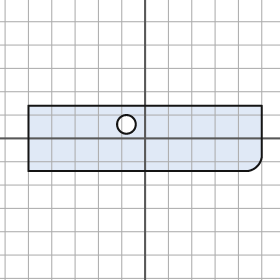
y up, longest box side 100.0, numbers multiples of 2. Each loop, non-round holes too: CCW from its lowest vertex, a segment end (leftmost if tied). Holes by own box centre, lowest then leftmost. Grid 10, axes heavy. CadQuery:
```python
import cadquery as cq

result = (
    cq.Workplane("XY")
    .moveTo(-50.0, -14.0)
    .lineTo(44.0, -14.0)
    .threePointArc((48.0, -12.0), (50.0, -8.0))
    .lineTo(50.0, 14.0)
    .lineTo(-50.0, 14.0)
    .close()
    .moveTo(-8.0, 6.0)
    .circle(4.0)
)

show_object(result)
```